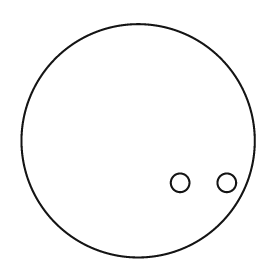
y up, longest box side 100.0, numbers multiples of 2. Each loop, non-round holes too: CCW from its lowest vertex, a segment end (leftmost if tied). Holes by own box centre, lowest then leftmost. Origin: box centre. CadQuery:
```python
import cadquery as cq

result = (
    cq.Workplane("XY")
    .moveTo(0.0, 0.0)
    .circle(50.0)
    .moveTo(18.0, -18.0)
    .circle(4.0)
    .moveTo(38.0, -18.0)
    .circle(4.0)
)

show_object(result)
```